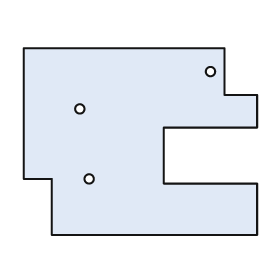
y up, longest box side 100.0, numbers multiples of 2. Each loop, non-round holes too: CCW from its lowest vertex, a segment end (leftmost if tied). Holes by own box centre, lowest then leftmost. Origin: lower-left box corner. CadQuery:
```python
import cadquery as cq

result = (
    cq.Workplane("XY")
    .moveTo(12.0, 0.0)
    .lineTo(100.0, 0.0)
    .lineTo(100.0, 22.0)
    .lineTo(60.0, 22.0)
    .lineTo(60.0, 46.0)
    .lineTo(100.0, 46.0)
    .lineTo(100.0, 60.0)
    .lineTo(86.0, 60.0)
    .lineTo(86.0, 80.0)
    .lineTo(0.0, 80.0)
    .lineTo(0.0, 24.0)
    .lineTo(12.0, 24.0)
    .close()
    .moveTo(28.0, 24.0)
    .circle(2.0)
    .moveTo(24.0, 54.0)
    .circle(2.0)
    .moveTo(80.0, 70.0)
    .circle(2.0)
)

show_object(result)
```